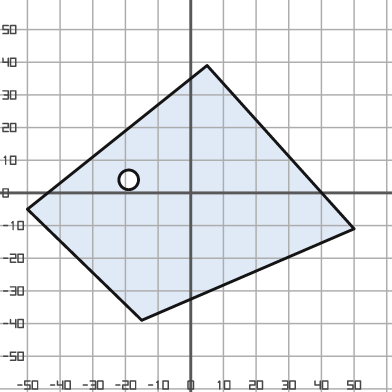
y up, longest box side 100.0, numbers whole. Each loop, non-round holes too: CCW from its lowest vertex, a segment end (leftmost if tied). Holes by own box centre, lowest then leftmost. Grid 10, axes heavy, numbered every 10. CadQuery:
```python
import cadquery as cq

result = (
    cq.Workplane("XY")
    .moveTo(-15.0, -39.0)
    .lineTo(50.0, -11.0)
    .lineTo(5.0, 39.0)
    .lineTo(-50.0, -5.0)
    .close()
    .moveTo(-19.0, 4.0)
    .circle(3.0)
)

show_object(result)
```